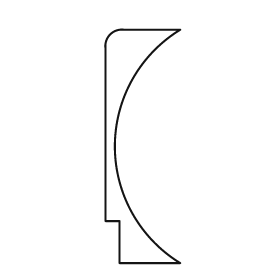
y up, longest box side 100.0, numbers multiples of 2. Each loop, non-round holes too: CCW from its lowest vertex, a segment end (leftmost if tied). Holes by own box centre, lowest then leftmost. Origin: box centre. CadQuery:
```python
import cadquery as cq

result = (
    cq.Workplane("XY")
    .moveTo(-10.0, -50.0)
    .lineTo(16.0, -50.0)
    .threePointArc((-12.0, 0.0), (16.0, 50.0))
    .lineTo(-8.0, 50.0)
    .threePointArc((-14.0, 48.0), (-16.0, 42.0))
    .lineTo(-16.0, -32.0)
    .lineTo(-10.0, -32.0)
    .close()
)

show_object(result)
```